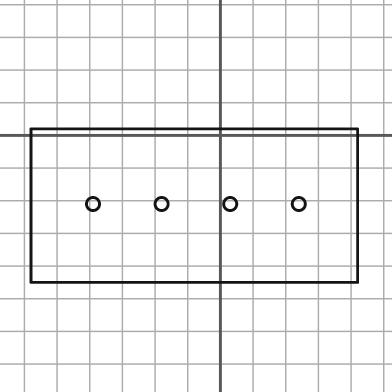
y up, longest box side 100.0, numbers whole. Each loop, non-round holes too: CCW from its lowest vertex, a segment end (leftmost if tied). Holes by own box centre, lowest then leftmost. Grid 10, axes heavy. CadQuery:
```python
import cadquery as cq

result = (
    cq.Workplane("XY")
    .moveTo(-58.0, -45.0)
    .lineTo(42.0, -45.0)
    .lineTo(42.0, 2.0)
    .lineTo(-58.0, 2.0)
    .close()
    .moveTo(-39.0, -21.0)
    .circle(2.0)
    .moveTo(-18.0, -21.0)
    .circle(2.0)
    .moveTo(3.0, -21.0)
    .circle(2.0)
    .moveTo(24.0, -21.0)
    .circle(2.0)
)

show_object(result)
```